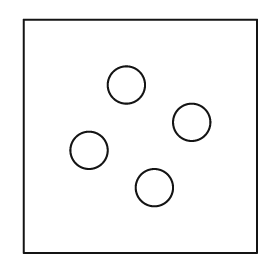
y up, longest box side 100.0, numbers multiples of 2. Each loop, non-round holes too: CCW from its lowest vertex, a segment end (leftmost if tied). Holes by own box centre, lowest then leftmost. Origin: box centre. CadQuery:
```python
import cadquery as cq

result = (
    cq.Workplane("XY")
    .moveTo(-50.0, -50.0)
    .lineTo(50.0, -50.0)
    .lineTo(50.0, 50.0)
    .lineTo(-50.0, 50.0)
    .close()
    .moveTo(6.0, -22.0)
    .circle(8.0)
    .moveTo(-22.0, -6.0)
    .circle(8.0)
    .moveTo(22.0, 6.0)
    .circle(8.0)
    .moveTo(-6.0, 22.0)
    .circle(8.0)
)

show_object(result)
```